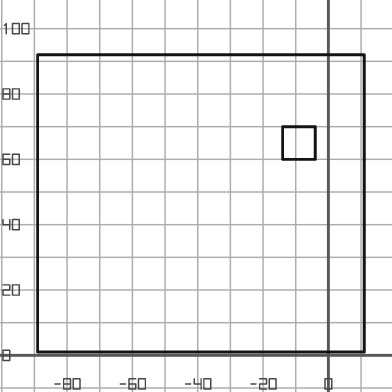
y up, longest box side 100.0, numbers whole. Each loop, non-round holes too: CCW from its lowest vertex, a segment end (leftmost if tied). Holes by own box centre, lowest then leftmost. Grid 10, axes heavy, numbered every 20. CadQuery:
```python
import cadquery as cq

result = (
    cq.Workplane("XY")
    .moveTo(-89.0, 1.0)
    .lineTo(11.0, 1.0)
    .lineTo(11.0, 92.0)
    .lineTo(-89.0, 92.0)
    .close()
    .moveTo(-14.0, 60.0)
    .lineTo(-4.0, 60.0)
    .lineTo(-4.0, 70.0)
    .lineTo(-14.0, 70.0)
    .close()
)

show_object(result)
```